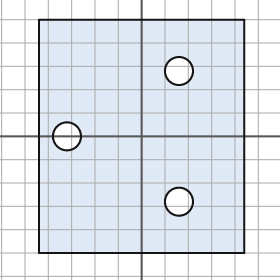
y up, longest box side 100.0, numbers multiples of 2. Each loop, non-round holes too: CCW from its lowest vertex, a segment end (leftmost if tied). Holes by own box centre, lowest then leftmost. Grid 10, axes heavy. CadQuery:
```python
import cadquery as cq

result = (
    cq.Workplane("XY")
    .moveTo(-44.0, -50.0)
    .lineTo(44.0, -50.0)
    .lineTo(44.0, 50.0)
    .lineTo(-44.0, 50.0)
    .close()
    .moveTo(16.0, -28.0)
    .circle(6.0)
    .moveTo(-32.0, 0.0)
    .circle(6.0)
    .moveTo(16.0, 28.0)
    .circle(6.0)
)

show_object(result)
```